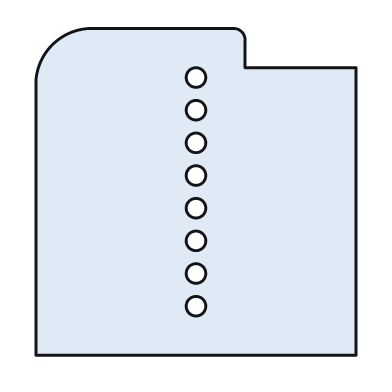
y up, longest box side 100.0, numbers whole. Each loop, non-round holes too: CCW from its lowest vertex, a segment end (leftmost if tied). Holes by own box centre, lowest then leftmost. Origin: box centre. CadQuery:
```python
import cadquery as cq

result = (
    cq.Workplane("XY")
    .moveTo(-49.0, -50.0)
    .lineTo(49.0, -50.0)
    .lineTo(49.0, 38.0)
    .lineTo(15.0, 38.0)
    .lineTo(15.0, 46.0)
    .threePointArc((14.0, 49.0), (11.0, 50.0))
    .lineTo(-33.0, 50.0)
    .threePointArc((-44.0, 45.0), (-49.0, 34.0))
    .close()
    .moveTo(0.0, -35.0)
    .circle(3.0)
    .moveTo(0.0, -25.0)
    .circle(3.0)
    .moveTo(0.0, -15.0)
    .circle(3.0)
    .moveTo(0.0, -5.0)
    .circle(3.0)
    .moveTo(0.0, 5.0)
    .circle(3.0)
    .moveTo(0.0, 15.0)
    .circle(3.0)
    .moveTo(0.0, 25.0)
    .circle(3.0)
    .moveTo(0.0, 35.0)
    .circle(3.0)
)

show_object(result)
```